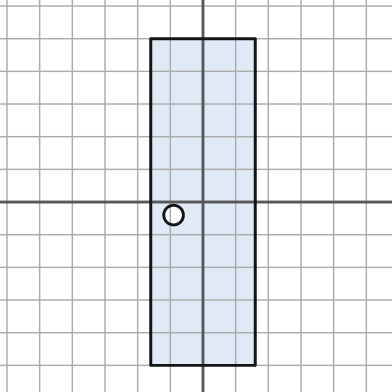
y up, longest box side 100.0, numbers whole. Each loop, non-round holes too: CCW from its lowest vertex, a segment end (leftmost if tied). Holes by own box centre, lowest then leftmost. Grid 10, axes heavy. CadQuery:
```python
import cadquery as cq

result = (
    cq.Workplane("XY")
    .moveTo(-16.0, -50.0)
    .lineTo(16.0, -50.0)
    .lineTo(16.0, 50.0)
    .lineTo(-16.0, 50.0)
    .close()
    .moveTo(-9.0, -4.0)
    .circle(3.0)
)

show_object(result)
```